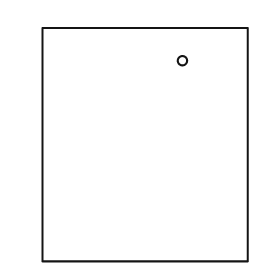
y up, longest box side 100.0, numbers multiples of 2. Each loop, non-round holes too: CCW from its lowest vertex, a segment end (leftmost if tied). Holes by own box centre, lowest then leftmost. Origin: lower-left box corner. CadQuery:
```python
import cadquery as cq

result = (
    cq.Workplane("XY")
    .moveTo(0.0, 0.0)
    .lineTo(88.0, 0.0)
    .lineTo(88.0, 100.0)
    .lineTo(0.0, 100.0)
    .close()
    .moveTo(60.0, 86.0)
    .circle(2.0)
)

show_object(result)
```